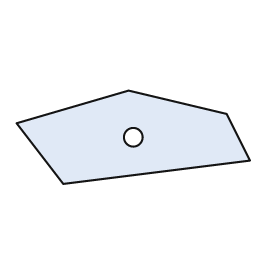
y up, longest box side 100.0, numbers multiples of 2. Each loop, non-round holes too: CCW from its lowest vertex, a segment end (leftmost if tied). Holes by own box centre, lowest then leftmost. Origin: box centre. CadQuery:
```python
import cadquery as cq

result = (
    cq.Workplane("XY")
    .moveTo(-30.0, -20.0)
    .lineTo(50.0, -10.0)
    .lineTo(40.0, 10.0)
    .lineTo(-2.0, 20.0)
    .lineTo(-50.0, 6.0)
    .close()
    .moveTo(0.0, 0.0)
    .circle(4.0)
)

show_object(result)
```